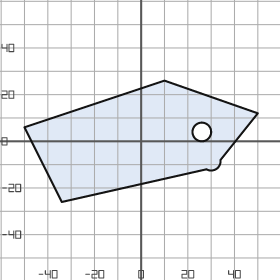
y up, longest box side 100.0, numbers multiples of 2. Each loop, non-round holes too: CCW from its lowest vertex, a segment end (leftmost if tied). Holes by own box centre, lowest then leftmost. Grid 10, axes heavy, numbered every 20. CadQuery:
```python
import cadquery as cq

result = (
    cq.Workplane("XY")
    .moveTo(-34.0, -26.0)
    .lineTo(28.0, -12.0)
    .threePointArc((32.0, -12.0), (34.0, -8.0))
    .lineTo(50.0, 12.0)
    .lineTo(10.0, 26.0)
    .lineTo(-50.0, 6.0)
    .close()
    .moveTo(26.0, 4.0)
    .circle(4.0)
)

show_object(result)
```